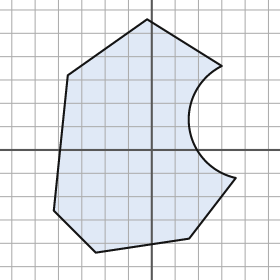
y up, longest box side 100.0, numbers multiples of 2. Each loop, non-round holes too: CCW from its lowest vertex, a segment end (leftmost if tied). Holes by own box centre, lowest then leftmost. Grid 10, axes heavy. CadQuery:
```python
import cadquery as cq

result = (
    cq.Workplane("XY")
    .moveTo(-24.0, -44.0)
    .lineTo(16.0, -38.0)
    .lineTo(36.0, -12.0)
    .threePointArc((16.0, 10.0), (30.0, 36.0))
    .lineTo(-2.0, 56.0)
    .lineTo(-36.0, 32.0)
    .lineTo(-42.0, -26.0)
    .close()
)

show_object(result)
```